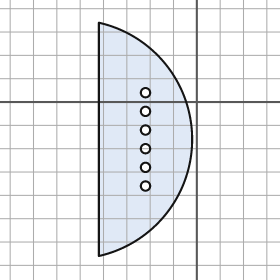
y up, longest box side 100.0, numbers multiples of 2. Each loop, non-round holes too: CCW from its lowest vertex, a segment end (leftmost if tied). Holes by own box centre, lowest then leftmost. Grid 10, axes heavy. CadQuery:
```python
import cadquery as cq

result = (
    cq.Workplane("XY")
    .moveTo(-42.0, -66.0)
    .threePointArc((-2.0, -16.0), (-42.0, 34.0))
    .close()
    .moveTo(-22.0, -36.0)
    .circle(2.0)
    .moveTo(-22.0, -28.0)
    .circle(2.0)
    .moveTo(-22.0, -20.0)
    .circle(2.0)
    .moveTo(-22.0, -12.0)
    .circle(2.0)
    .moveTo(-22.0, -4.0)
    .circle(2.0)
    .moveTo(-22.0, 4.0)
    .circle(2.0)
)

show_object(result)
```